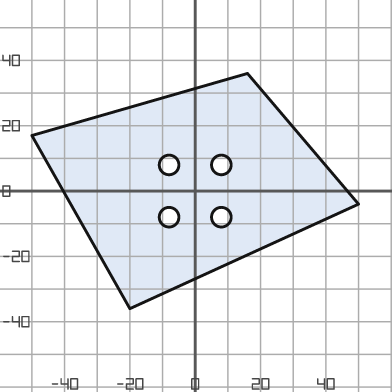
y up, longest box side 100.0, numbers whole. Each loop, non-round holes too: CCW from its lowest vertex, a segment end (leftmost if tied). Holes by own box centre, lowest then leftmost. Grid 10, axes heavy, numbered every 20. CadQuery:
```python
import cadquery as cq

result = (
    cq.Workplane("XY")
    .moveTo(-20.0, -36.0)
    .lineTo(50.0, -4.0)
    .lineTo(16.0, 36.0)
    .lineTo(-50.0, 17.0)
    .close()
    .moveTo(-8.0, -8.0)
    .circle(3.0)
    .moveTo(8.0, -8.0)
    .circle(3.0)
    .moveTo(-8.0, 8.0)
    .circle(3.0)
    .moveTo(8.0, 8.0)
    .circle(3.0)
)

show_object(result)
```